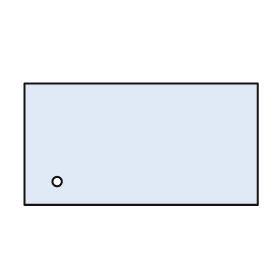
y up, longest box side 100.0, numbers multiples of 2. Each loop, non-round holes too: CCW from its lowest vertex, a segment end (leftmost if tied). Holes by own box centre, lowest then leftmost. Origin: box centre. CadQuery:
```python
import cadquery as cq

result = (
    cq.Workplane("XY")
    .moveTo(-50.0, -26.0)
    .lineTo(50.0, -26.0)
    .lineTo(50.0, 26.0)
    .lineTo(-50.0, 26.0)
    .close()
    .moveTo(-36.0, -16.0)
    .circle(2.0)
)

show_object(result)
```